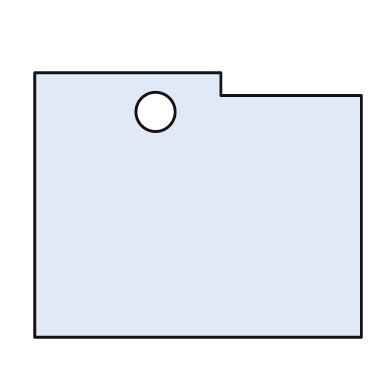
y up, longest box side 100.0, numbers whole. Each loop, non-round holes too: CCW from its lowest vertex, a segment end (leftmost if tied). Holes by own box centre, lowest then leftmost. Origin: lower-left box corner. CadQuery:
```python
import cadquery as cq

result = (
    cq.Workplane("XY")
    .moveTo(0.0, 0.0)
    .lineTo(100.0, 0.0)
    .lineTo(100.0, 74.0)
    .lineTo(57.0, 74.0)
    .lineTo(57.0, 81.0)
    .lineTo(0.0, 81.0)
    .close()
    .moveTo(37.0, 69.0)
    .circle(6.0)
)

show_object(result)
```